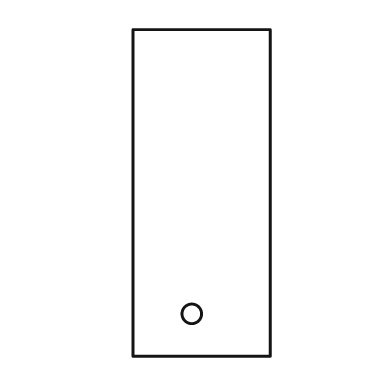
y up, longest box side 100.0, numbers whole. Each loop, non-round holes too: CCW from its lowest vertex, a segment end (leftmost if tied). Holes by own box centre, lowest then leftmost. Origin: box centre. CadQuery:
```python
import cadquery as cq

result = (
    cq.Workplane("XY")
    .moveTo(-21.0, -50.0)
    .lineTo(21.0, -50.0)
    .lineTo(21.0, 50.0)
    .lineTo(-21.0, 50.0)
    .close()
    .moveTo(-3.0, -37.0)
    .circle(3.0)
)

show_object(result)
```